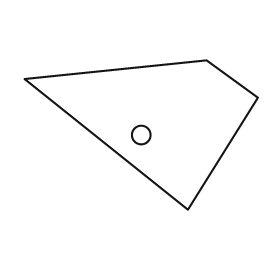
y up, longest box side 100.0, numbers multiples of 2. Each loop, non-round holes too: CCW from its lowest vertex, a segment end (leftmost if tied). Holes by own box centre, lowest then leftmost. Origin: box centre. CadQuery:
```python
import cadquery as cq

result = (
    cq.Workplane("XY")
    .moveTo(20.0, -32.0)
    .lineTo(50.0, 16.0)
    .lineTo(28.0, 32.0)
    .lineTo(-50.0, 24.0)
    .close()
    .moveTo(0.0, 0.0)
    .circle(4.0)
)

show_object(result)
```